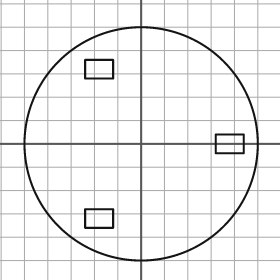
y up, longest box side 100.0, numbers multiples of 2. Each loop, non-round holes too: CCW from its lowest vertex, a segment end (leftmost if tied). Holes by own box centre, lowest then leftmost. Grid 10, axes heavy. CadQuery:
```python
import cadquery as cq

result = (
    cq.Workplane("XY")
    .moveTo(0.0, 0.0)
    .circle(50.0)
    .moveTo(-24.0, -36.0)
    .lineTo(-12.0, -36.0)
    .lineTo(-12.0, -28.0)
    .lineTo(-24.0, -28.0)
    .close()
    .moveTo(32.0, -4.0)
    .lineTo(44.0, -4.0)
    .lineTo(44.0, 4.0)
    .lineTo(32.0, 4.0)
    .close()
    .moveTo(-24.0, 28.0)
    .lineTo(-12.0, 28.0)
    .lineTo(-12.0, 36.0)
    .lineTo(-24.0, 36.0)
    .close()
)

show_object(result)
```